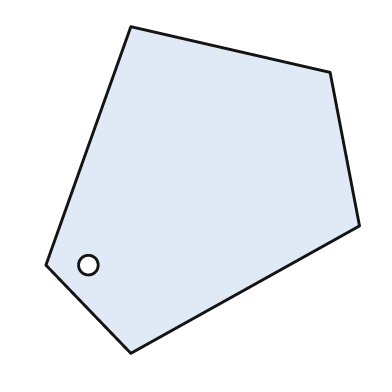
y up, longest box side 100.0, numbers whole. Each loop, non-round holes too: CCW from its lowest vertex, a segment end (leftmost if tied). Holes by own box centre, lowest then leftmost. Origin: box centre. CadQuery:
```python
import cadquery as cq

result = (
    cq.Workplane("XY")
    .moveTo(-22.0, -50.0)
    .lineTo(48.0, -11.0)
    .lineTo(39.0, 36.0)
    .lineTo(-22.0, 50.0)
    .lineTo(-48.0, -23.0)
    .close()
    .moveTo(-35.0, -23.0)
    .circle(3.0)
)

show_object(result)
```